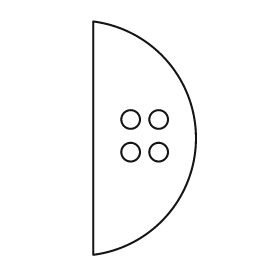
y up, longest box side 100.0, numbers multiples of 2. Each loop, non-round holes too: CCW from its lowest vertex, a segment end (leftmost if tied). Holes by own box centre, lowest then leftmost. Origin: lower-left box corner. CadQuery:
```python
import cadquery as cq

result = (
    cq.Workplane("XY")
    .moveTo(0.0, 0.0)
    .threePointArc((44.0, 50.0), (0.0, 100.0))
    .close()
    .moveTo(16.0, 44.0)
    .circle(4.0)
    .moveTo(28.0, 44.0)
    .circle(4.0)
    .moveTo(16.0, 58.0)
    .circle(4.0)
    .moveTo(28.0, 58.0)
    .circle(4.0)
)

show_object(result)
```